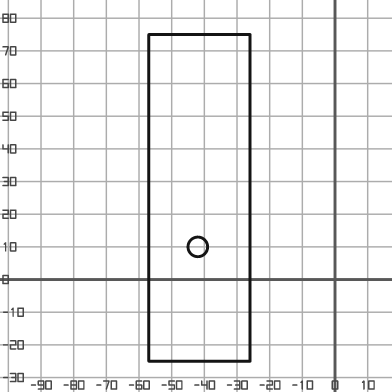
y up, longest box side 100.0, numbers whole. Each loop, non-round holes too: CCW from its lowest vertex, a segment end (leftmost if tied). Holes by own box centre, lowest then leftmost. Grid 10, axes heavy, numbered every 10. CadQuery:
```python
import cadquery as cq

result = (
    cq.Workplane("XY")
    .moveTo(-57.0, -25.0)
    .lineTo(-26.0, -25.0)
    .lineTo(-26.0, 75.0)
    .lineTo(-57.0, 75.0)
    .close()
    .moveTo(-42.0, 10.0)
    .circle(3.0)
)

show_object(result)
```